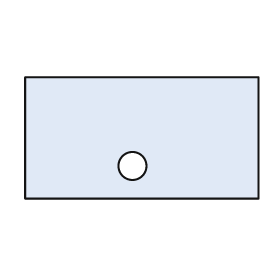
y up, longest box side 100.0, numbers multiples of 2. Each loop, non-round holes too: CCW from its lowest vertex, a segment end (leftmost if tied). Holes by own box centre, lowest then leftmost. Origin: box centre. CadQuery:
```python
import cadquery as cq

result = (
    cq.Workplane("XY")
    .moveTo(-50.0, -26.0)
    .lineTo(50.0, -26.0)
    .lineTo(50.0, 26.0)
    .lineTo(-50.0, 26.0)
    .close()
    .moveTo(-4.0, -12.0)
    .circle(6.0)
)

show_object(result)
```